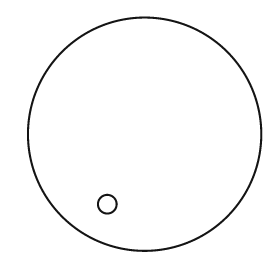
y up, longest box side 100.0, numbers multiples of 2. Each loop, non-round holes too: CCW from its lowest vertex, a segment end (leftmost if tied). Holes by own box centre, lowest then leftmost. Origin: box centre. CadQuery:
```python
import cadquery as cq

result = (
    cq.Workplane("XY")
    .moveTo(0.0, 0.0)
    .circle(50.0)
    .moveTo(-16.0, -30.0)
    .circle(4.0)
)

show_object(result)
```